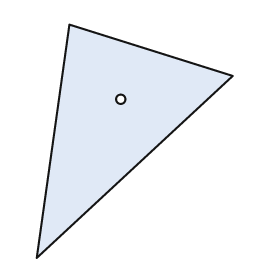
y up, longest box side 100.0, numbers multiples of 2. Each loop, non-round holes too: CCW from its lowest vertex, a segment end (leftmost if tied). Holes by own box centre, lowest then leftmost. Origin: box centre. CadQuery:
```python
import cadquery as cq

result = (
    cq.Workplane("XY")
    .moveTo(-42.0, -50.0)
    .lineTo(42.0, 28.0)
    .lineTo(-28.0, 50.0)
    .close()
    .moveTo(-6.0, 18.0)
    .circle(2.0)
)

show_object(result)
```